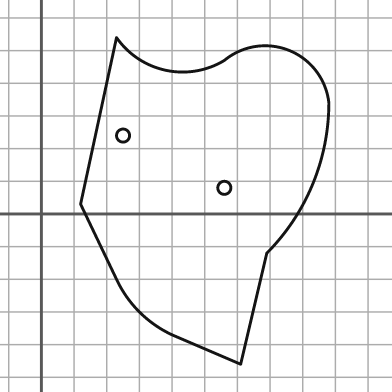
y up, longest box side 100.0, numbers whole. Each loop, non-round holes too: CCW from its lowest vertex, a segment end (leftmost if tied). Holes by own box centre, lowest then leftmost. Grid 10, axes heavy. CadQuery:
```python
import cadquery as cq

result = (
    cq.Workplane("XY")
    .moveTo(61.0, -46.0)
    .lineTo(69.0, -12.0)
    .threePointArc((83.0, 9.0), (88.0, 34.0))
    .threePointArc((76.0, 50.0), (56.0, 47.0))
    .threePointArc((38.0, 44.0), (23.0, 54.0))
    .lineTo(12.0, 3.0)
    .lineTo(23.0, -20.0)
    .threePointArc((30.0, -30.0), (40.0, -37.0))
    .close()
    .moveTo(56.0, 8.0)
    .circle(2.0)
    .moveTo(25.0, 24.0)
    .circle(2.0)
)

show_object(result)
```